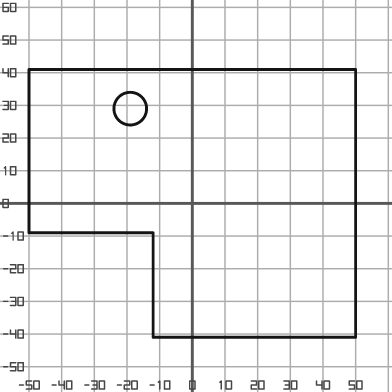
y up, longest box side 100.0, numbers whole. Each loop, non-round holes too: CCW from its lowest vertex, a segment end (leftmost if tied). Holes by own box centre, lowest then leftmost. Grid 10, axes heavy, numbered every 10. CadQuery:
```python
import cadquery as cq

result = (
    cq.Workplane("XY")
    .moveTo(-12.0, -41.0)
    .lineTo(50.0, -41.0)
    .lineTo(50.0, 41.0)
    .lineTo(-50.0, 41.0)
    .lineTo(-50.0, -9.0)
    .lineTo(-12.0, -9.0)
    .close()
    .moveTo(-19.0, 29.0)
    .circle(5.0)
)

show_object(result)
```